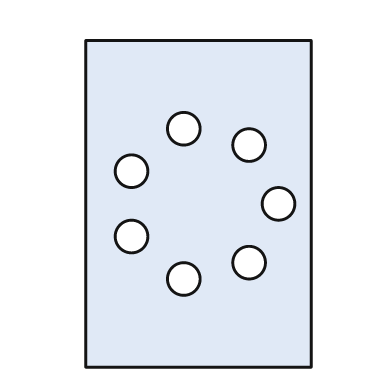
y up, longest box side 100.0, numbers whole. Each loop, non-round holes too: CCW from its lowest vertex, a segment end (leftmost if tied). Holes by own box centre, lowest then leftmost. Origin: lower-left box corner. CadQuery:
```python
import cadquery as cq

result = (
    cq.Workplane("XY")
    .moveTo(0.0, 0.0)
    .lineTo(69.0, 0.0)
    .lineTo(69.0, 100.0)
    .lineTo(0.0, 100.0)
    .close()
    .moveTo(30.0, 27.0)
    .circle(5.0)
    .moveTo(50.0, 32.0)
    .circle(5.0)
    .moveTo(14.0, 40.0)
    .circle(5.0)
    .moveTo(59.0, 50.0)
    .circle(5.0)
    .moveTo(14.0, 60.0)
    .circle(5.0)
    .moveTo(50.0, 68.0)
    .circle(5.0)
    .moveTo(30.0, 73.0)
    .circle(5.0)
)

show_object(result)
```